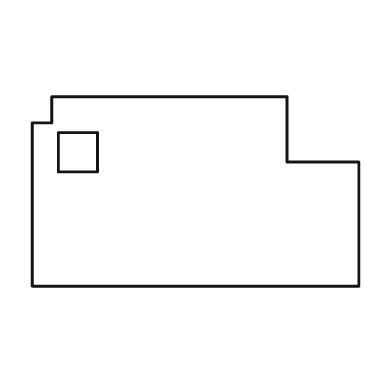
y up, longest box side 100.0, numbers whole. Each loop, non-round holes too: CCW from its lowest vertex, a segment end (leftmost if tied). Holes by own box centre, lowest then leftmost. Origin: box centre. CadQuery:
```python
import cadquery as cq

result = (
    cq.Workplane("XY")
    .moveTo(-50.0, -29.0)
    .lineTo(50.0, -29.0)
    .lineTo(50.0, 9.0)
    .lineTo(28.0, 9.0)
    .lineTo(28.0, 29.0)
    .lineTo(-44.0, 29.0)
    .lineTo(-44.0, 21.0)
    .lineTo(-50.0, 21.0)
    .close()
    .moveTo(-42.0, 6.0)
    .lineTo(-30.0, 6.0)
    .lineTo(-30.0, 18.0)
    .lineTo(-42.0, 18.0)
    .close()
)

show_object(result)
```